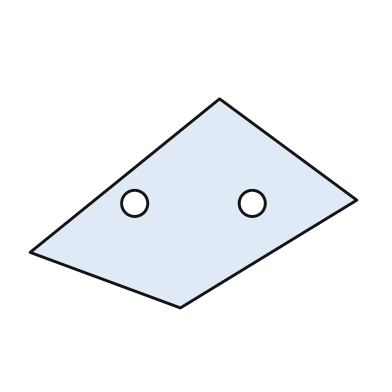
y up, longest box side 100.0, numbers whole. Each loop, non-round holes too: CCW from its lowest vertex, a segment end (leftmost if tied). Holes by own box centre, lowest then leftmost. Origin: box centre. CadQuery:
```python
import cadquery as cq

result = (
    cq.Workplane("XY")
    .moveTo(-4.0, -32.0)
    .lineTo(50.0, 1.0)
    .lineTo(8.0, 32.0)
    .lineTo(-50.0, -15.0)
    .close()
    .moveTo(-18.0, 0.0)
    .circle(4.0)
    .moveTo(18.0, 0.0)
    .circle(4.0)
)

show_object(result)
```